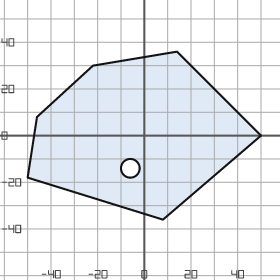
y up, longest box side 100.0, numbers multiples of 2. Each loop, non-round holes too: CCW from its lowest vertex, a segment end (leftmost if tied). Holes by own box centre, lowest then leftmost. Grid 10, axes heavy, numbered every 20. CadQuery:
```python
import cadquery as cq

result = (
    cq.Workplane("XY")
    .moveTo(8.0, -36.0)
    .lineTo(50.0, 0.0)
    .lineTo(14.0, 36.0)
    .lineTo(-22.0, 30.0)
    .lineTo(-46.0, 8.0)
    .lineTo(-50.0, -18.0)
    .close()
    .moveTo(-6.0, -14.0)
    .circle(4.0)
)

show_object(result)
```